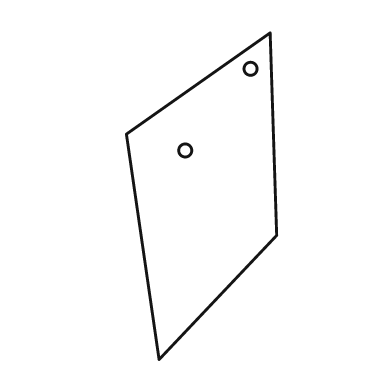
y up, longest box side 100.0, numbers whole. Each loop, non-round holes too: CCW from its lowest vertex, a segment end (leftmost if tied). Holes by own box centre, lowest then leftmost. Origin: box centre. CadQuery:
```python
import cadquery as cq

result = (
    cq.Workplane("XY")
    .moveTo(-13.0, -50.0)
    .lineTo(23.0, -12.0)
    .lineTo(21.0, 50.0)
    .lineTo(-23.0, 19.0)
    .close()
    .moveTo(-5.0, 14.0)
    .circle(2.0)
    .moveTo(15.0, 39.0)
    .circle(2.0)
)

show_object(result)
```